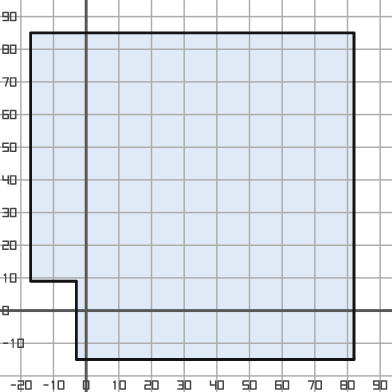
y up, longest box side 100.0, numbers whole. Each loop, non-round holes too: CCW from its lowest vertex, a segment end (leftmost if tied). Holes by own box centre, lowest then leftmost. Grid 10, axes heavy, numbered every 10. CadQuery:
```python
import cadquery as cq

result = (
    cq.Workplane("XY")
    .moveTo(-3.0, -15.0)
    .lineTo(82.0, -15.0)
    .lineTo(82.0, 85.0)
    .lineTo(-17.0, 85.0)
    .lineTo(-17.0, 9.0)
    .lineTo(-3.0, 9.0)
    .close()
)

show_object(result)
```